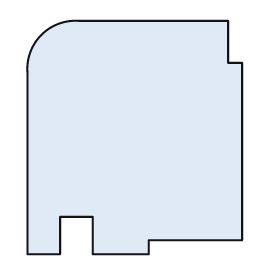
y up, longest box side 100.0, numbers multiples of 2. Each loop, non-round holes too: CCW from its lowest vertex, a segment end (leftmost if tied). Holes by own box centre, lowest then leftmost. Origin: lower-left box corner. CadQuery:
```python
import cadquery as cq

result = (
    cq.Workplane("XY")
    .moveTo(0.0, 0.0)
    .lineTo(14.0, 0.0)
    .lineTo(14.0, 16.0)
    .lineTo(28.0, 16.0)
    .lineTo(28.0, 0.0)
    .lineTo(52.0, 0.0)
    .lineTo(52.0, 6.0)
    .lineTo(92.0, 6.0)
    .lineTo(92.0, 82.0)
    .lineTo(86.0, 82.0)
    .lineTo(86.0, 100.0)
    .lineTo(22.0, 100.0)
    .threePointArc((6.0, 94.0), (0.0, 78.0))
    .close()
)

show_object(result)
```